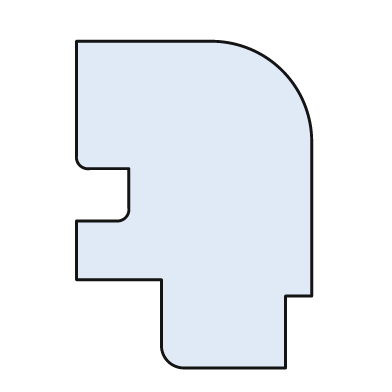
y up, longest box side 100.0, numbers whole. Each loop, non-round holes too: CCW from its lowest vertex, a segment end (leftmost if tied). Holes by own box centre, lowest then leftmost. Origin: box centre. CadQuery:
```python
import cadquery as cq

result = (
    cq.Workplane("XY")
    .moveTo(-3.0, -50.0)
    .lineTo(28.0, -50.0)
    .lineTo(28.0, -28.0)
    .lineTo(36.0, -28.0)
    .lineTo(36.0, 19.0)
    .threePointArc((27.0, 41.0), (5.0, 50.0))
    .lineTo(-36.0, 50.0)
    .lineTo(-36.0, 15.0)
    .threePointArc((-35.0, 12.0), (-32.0, 11.0))
    .lineTo(-20.0, 11.0)
    .lineTo(-20.0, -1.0)
    .threePointArc((-21.0, -4.0), (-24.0, -5.0))
    .lineTo(-36.0, -5.0)
    .lineTo(-36.0, -23.0)
    .lineTo(-10.0, -23.0)
    .lineTo(-10.0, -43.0)
    .threePointArc((-8.0, -48.0), (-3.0, -50.0))
    .close()
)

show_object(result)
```